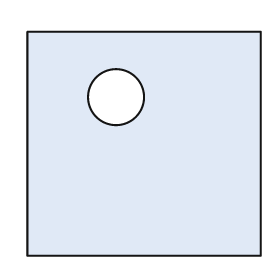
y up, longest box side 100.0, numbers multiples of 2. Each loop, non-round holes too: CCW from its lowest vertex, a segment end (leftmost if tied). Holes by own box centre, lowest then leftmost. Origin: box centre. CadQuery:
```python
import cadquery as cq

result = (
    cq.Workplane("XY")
    .moveTo(-50.0, -48.0)
    .lineTo(50.0, -48.0)
    .lineTo(50.0, 48.0)
    .lineTo(-50.0, 48.0)
    .close()
    .moveTo(-12.0, 20.0)
    .circle(12.0)
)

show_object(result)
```